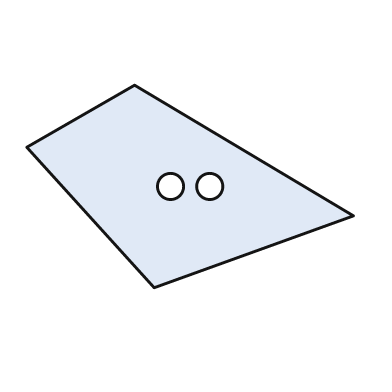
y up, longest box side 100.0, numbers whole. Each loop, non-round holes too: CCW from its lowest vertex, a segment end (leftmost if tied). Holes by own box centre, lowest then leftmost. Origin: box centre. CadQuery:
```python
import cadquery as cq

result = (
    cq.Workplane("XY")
    .moveTo(-11.0, -31.0)
    .lineTo(50.0, -9.0)
    .lineTo(-17.0, 31.0)
    .lineTo(-50.0, 12.0)
    .close()
    .moveTo(-6.0, 0.0)
    .circle(4.0)
    .moveTo(6.0, 0.0)
    .circle(4.0)
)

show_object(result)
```